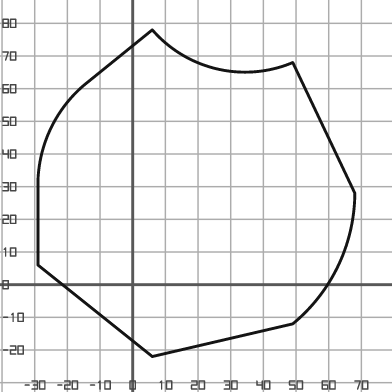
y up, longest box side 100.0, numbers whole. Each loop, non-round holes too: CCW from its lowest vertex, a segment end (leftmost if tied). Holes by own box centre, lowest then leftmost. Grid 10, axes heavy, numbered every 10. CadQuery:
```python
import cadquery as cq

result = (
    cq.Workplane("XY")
    .moveTo(6.0, -22.0)
    .lineTo(49.0, -12.0)
    .threePointArc((63.0, 6.0), (68.0, 28.0))
    .lineTo(49.0, 68.0)
    .threePointArc((26.0, 66.0), (6.0, 78.0))
    .lineTo(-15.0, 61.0)
    .threePointArc((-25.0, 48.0), (-29.0, 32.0))
    .lineTo(-29.0, 6.0)
    .close()
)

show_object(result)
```